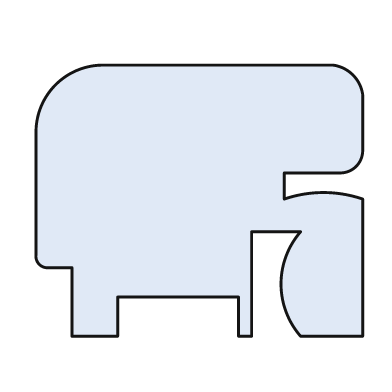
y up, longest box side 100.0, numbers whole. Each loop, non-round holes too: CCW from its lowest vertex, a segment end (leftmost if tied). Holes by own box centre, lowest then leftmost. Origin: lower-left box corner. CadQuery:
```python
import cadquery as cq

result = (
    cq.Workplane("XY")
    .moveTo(11.0, 0.0)
    .lineTo(25.0, 0.0)
    .lineTo(25.0, 12.0)
    .lineTo(62.0, 12.0)
    .lineTo(62.0, 0.0)
    .lineTo(66.0, 0.0)
    .lineTo(66.0, 32.0)
    .lineTo(81.0, 32.0)
    .threePointArc((75.0, 16.0), (81.0, 0.0))
    .lineTo(100.0, 0.0)
    .lineTo(100.0, 42.0)
    .threePointArc((88.0, 44.0), (76.0, 42.0))
    .lineTo(76.0, 50.0)
    .lineTo(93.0, 50.0)
    .threePointArc((98.0, 52.0), (100.0, 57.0))
    .lineTo(100.0, 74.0)
    .threePointArc((97.0, 80.0), (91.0, 83.0))
    .lineTo(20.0, 83.0)
    .threePointArc((6.0, 77.0), (0.0, 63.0))
    .lineTo(0.0, 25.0)
    .threePointArc((1.0, 22.0), (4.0, 21.0))
    .lineTo(11.0, 21.0)
    .close()
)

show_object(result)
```